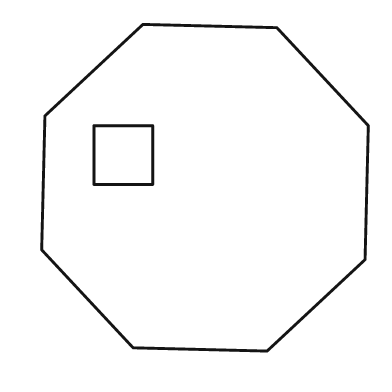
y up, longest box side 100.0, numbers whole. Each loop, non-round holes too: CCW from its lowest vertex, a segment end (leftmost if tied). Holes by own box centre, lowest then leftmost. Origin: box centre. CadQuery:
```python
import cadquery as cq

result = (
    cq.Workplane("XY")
    .moveTo(19.0, -50.0)
    .lineTo(49.0, -22.0)
    .lineTo(50.0, 19.0)
    .lineTo(22.0, 49.0)
    .lineTo(-19.0, 50.0)
    .lineTo(-49.0, 22.0)
    .lineTo(-50.0, -19.0)
    .lineTo(-22.0, -49.0)
    .close()
    .moveTo(-34.0, 1.0)
    .lineTo(-16.0, 1.0)
    .lineTo(-16.0, 19.0)
    .lineTo(-34.0, 19.0)
    .close()
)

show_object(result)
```